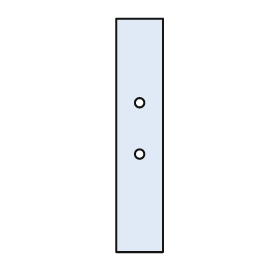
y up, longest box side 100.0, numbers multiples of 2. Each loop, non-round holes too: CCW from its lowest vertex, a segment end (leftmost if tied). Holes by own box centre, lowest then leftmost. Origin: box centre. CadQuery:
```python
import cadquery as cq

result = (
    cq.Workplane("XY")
    .moveTo(-10.0, -50.0)
    .lineTo(10.0, -50.0)
    .lineTo(10.0, 50.0)
    .lineTo(-10.0, 50.0)
    .close()
    .moveTo(0.0, -8.0)
    .circle(2.0)
    .moveTo(0.0, 14.0)
    .circle(2.0)
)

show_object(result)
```